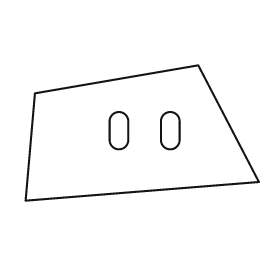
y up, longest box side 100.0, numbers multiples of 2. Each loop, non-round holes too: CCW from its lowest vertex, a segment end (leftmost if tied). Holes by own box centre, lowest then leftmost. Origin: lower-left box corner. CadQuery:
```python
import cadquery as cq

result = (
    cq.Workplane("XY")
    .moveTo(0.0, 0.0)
    .lineTo(100.0, 8.0)
    .lineTo(74.0, 58.0)
    .lineTo(4.0, 46.0)
    .close()
    .moveTo(36.0, 26.0)
    .threePointArc((40.0, 22.0), (44.0, 26.0))
    .lineTo(44.0, 34.0)
    .threePointArc((40.0, 38.0), (36.0, 34.0))
    .close()
    .moveTo(58.0, 26.0)
    .threePointArc((62.0, 22.0), (66.0, 26.0))
    .lineTo(66.0, 34.0)
    .threePointArc((62.0, 38.0), (58.0, 34.0))
    .close()
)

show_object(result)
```